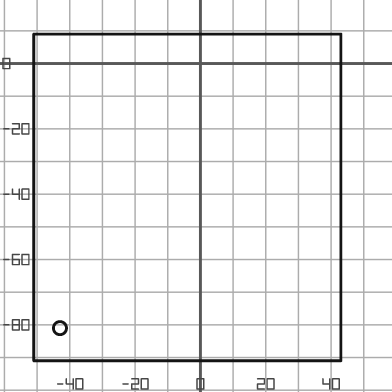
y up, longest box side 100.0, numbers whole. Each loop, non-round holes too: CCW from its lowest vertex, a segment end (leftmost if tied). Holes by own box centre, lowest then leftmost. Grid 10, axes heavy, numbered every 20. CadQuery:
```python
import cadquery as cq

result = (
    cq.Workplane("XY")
    .moveTo(-51.0, -91.0)
    .lineTo(43.0, -91.0)
    .lineTo(43.0, 9.0)
    .lineTo(-51.0, 9.0)
    .close()
    .moveTo(-43.0, -81.0)
    .circle(2.0)
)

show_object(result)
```